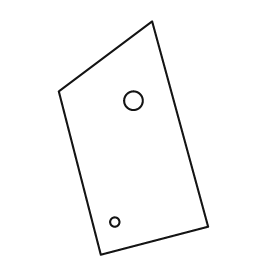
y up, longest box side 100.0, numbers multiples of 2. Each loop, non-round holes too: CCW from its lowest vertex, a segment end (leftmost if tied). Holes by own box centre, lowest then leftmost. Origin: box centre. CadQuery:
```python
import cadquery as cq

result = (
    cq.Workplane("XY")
    .moveTo(-14.0, -50.0)
    .lineTo(32.0, -38.0)
    .lineTo(8.0, 50.0)
    .lineTo(-32.0, 20.0)
    .close()
    .moveTo(-8.0, -36.0)
    .circle(2.0)
    .moveTo(0.0, 16.0)
    .circle(4.0)
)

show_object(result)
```